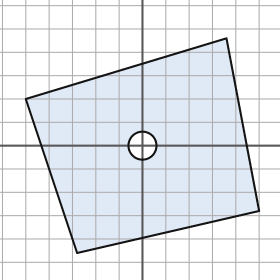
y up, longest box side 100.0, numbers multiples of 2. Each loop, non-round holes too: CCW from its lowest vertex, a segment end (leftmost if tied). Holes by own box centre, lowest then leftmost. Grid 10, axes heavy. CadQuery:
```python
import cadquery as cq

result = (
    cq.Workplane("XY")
    .moveTo(-28.0, -46.0)
    .lineTo(50.0, -28.0)
    .lineTo(36.0, 46.0)
    .lineTo(-50.0, 20.0)
    .close()
    .moveTo(0.0, 0.0)
    .circle(6.0)
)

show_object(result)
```